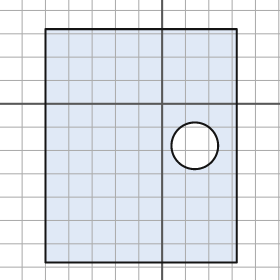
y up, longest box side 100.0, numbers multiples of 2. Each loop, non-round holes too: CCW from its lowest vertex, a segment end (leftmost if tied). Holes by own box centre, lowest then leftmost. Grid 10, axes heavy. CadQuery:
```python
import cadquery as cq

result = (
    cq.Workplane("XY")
    .moveTo(-50.0, -68.0)
    .lineTo(32.0, -68.0)
    .lineTo(32.0, 32.0)
    .lineTo(-50.0, 32.0)
    .close()
    .moveTo(14.0, -18.0)
    .circle(10.0)
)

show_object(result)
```